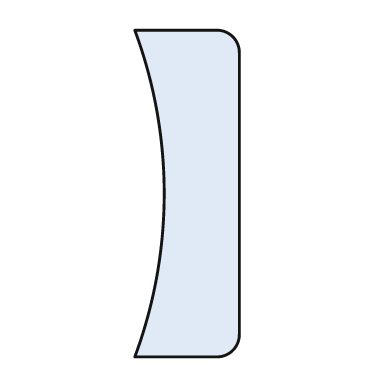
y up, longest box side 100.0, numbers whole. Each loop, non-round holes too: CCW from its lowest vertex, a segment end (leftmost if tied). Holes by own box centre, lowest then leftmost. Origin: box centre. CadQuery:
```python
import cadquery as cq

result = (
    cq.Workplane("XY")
    .moveTo(-16.0, -50.0)
    .lineTo(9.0, -50.0)
    .threePointArc((14.0, -48.0), (16.0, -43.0))
    .lineTo(16.0, 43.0)
    .threePointArc((14.0, 48.0), (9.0, 50.0))
    .lineTo(-16.0, 50.0)
    .threePointArc((-7.0, 0.0), (-16.0, -50.0))
    .close()
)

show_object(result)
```